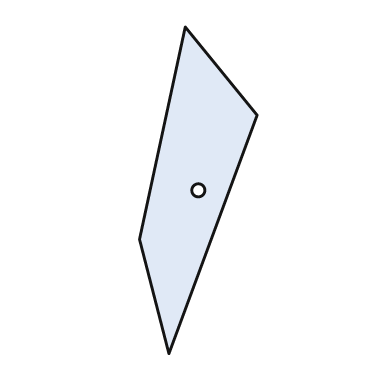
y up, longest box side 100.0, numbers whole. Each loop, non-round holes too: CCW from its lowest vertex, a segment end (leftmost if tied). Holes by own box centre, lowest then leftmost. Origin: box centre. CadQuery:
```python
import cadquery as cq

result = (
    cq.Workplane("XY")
    .moveTo(-9.0, -50.0)
    .lineTo(18.0, 23.0)
    .lineTo(-4.0, 50.0)
    .lineTo(-18.0, -15.0)
    .close()
    .moveTo(0.0, 0.0)
    .circle(2.0)
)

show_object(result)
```